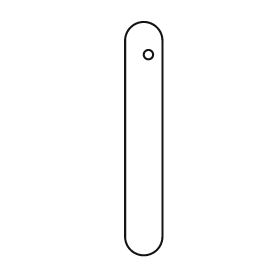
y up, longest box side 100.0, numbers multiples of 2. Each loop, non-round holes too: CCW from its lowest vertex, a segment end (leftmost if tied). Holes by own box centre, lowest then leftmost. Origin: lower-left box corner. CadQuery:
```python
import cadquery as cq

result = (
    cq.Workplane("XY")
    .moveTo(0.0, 8.0)
    .threePointArc((8.0, 0.0), (16.0, 8.0))
    .lineTo(16.0, 92.0)
    .threePointArc((8.0, 100.0), (0.0, 92.0))
    .close()
    .moveTo(10.0, 86.0)
    .circle(2.0)
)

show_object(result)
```